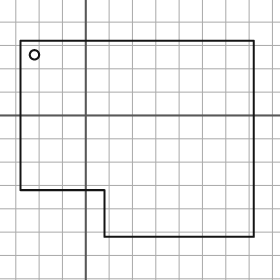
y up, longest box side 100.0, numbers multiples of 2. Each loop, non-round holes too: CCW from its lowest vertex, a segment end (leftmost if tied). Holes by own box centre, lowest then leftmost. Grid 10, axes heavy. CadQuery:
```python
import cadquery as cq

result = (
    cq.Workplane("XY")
    .moveTo(8.0, -52.0)
    .lineTo(72.0, -52.0)
    .lineTo(72.0, 32.0)
    .lineTo(-28.0, 32.0)
    .lineTo(-28.0, -32.0)
    .lineTo(8.0, -32.0)
    .close()
    .moveTo(-22.0, 26.0)
    .circle(2.0)
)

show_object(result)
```